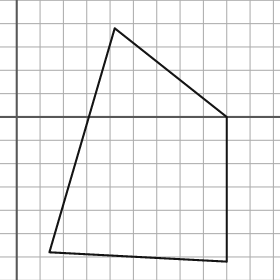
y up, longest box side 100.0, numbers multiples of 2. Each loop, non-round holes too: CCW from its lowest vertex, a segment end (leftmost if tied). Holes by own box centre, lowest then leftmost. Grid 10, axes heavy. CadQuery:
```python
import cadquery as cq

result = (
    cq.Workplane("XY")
    .moveTo(90.0, -62.0)
    .lineTo(90.0, 0.0)
    .lineTo(42.0, 38.0)
    .lineTo(14.0, -58.0)
    .close()
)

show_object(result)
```